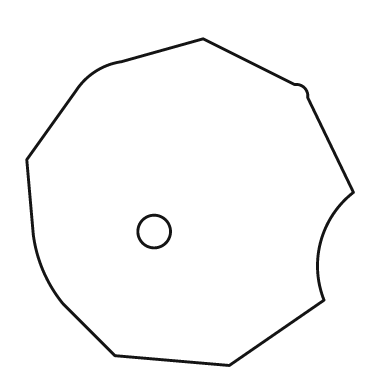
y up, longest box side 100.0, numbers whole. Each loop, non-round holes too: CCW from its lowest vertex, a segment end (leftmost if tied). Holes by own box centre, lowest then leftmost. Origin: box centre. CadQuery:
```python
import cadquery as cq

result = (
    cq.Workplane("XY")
    .moveTo(12.0, -50.0)
    .lineTo(41.0, -30.0)
    .threePointArc((40.0, -12.0), (50.0, 3.0))
    .lineTo(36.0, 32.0)
    .threePointArc((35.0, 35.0), (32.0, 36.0))
    .lineTo(4.0, 50.0)
    .lineTo(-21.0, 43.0)
    .threePointArc((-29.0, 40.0), (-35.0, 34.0))
    .lineTo(-50.0, 13.0)
    .lineTo(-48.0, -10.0)
    .threePointArc((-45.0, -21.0), (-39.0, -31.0))
    .lineTo(-23.0, -47.0)
    .close()
    .moveTo(-11.0, -9.0)
    .circle(5.0)
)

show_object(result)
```